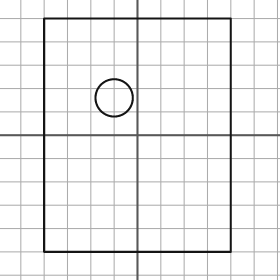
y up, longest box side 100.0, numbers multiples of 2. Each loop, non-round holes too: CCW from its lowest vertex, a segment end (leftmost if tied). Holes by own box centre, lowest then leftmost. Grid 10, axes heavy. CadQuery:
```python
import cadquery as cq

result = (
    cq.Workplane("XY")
    .moveTo(-40.0, -50.0)
    .lineTo(40.0, -50.0)
    .lineTo(40.0, 50.0)
    .lineTo(-40.0, 50.0)
    .close()
    .moveTo(-10.0, 16.0)
    .circle(8.0)
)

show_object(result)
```